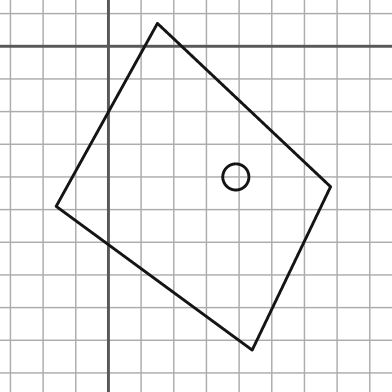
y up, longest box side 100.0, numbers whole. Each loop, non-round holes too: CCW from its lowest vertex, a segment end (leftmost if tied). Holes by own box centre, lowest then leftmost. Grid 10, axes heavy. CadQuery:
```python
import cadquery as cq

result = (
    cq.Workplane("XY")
    .moveTo(44.0, -93.0)
    .lineTo(68.0, -43.0)
    .lineTo(15.0, 7.0)
    .lineTo(-16.0, -49.0)
    .close()
    .moveTo(39.0, -40.0)
    .circle(4.0)
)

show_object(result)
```